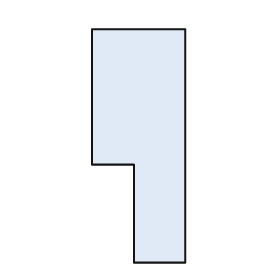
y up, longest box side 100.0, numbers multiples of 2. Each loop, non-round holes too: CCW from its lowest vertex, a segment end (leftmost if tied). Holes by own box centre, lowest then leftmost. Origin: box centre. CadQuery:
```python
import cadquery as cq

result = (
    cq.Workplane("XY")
    .moveTo(-2.0, -50.0)
    .lineTo(20.0, -50.0)
    .lineTo(20.0, 50.0)
    .lineTo(-20.0, 50.0)
    .lineTo(-20.0, -8.0)
    .lineTo(-2.0, -8.0)
    .close()
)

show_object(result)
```